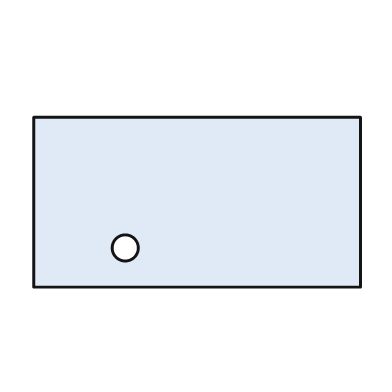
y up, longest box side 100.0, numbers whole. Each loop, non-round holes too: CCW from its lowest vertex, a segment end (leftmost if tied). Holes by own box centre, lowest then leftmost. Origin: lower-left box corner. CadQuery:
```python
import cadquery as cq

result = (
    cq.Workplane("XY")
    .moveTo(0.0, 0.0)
    .lineTo(100.0, 0.0)
    .lineTo(100.0, 52.0)
    .lineTo(0.0, 52.0)
    .close()
    .moveTo(28.0, 12.0)
    .circle(4.0)
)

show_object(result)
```